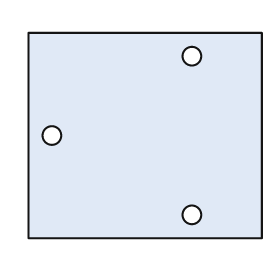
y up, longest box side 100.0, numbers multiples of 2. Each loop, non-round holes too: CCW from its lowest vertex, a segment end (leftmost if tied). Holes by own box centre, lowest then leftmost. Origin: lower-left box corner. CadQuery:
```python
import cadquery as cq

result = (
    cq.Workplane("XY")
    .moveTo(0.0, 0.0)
    .lineTo(100.0, 0.0)
    .lineTo(100.0, 88.0)
    .lineTo(0.0, 88.0)
    .close()
    .moveTo(70.0, 10.0)
    .circle(4.0)
    .moveTo(10.0, 44.0)
    .circle(4.0)
    .moveTo(70.0, 78.0)
    .circle(4.0)
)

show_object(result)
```